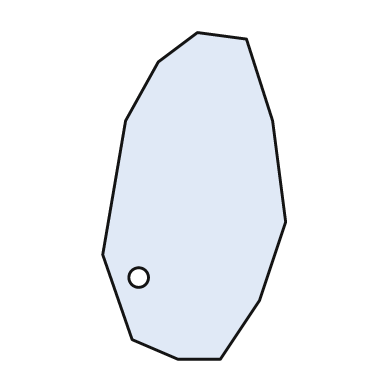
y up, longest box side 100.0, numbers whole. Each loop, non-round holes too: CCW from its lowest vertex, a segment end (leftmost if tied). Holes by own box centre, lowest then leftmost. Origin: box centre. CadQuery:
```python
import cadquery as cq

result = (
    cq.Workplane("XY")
    .moveTo(-5.0, -50.0)
    .lineTo(8.0, -50.0)
    .lineTo(20.0, -32.0)
    .lineTo(28.0, -8.0)
    .lineTo(24.0, 23.0)
    .lineTo(16.0, 48.0)
    .lineTo(1.0, 50.0)
    .lineTo(-11.0, 41.0)
    .lineTo(-21.0, 23.0)
    .lineTo(-28.0, -18.0)
    .lineTo(-19.0, -44.0)
    .close()
    .moveTo(-17.0, -25.0)
    .circle(3.0)
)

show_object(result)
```